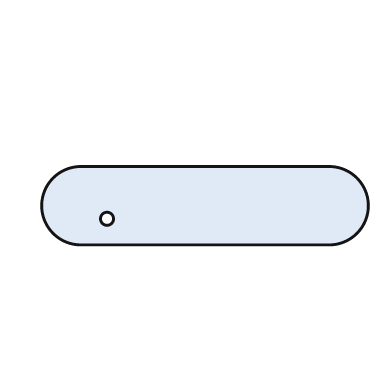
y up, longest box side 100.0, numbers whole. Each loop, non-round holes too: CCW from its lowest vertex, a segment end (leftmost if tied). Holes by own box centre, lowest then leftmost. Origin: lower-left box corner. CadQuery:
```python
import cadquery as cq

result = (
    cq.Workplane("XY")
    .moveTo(12.0, 0.0)
    .lineTo(88.0, 0.0)
    .threePointArc((100.0, 12.0), (88.0, 24.0))
    .lineTo(12.0, 24.0)
    .threePointArc((0.0, 12.0), (12.0, 0.0))
    .close()
    .moveTo(20.0, 8.0)
    .circle(2.0)
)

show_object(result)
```